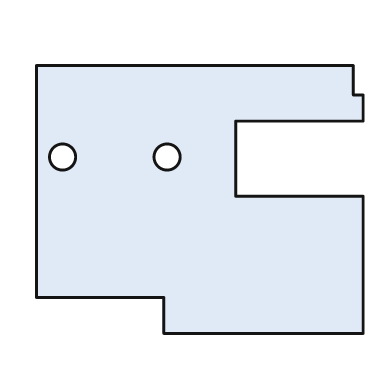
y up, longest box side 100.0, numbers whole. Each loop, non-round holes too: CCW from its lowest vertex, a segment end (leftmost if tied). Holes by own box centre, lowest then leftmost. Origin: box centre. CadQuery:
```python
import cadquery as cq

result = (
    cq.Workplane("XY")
    .moveTo(-11.0, -41.0)
    .lineTo(50.0, -41.0)
    .lineTo(50.0, 1.0)
    .lineTo(11.0, 1.0)
    .lineTo(11.0, 24.0)
    .lineTo(50.0, 24.0)
    .lineTo(50.0, 32.0)
    .lineTo(47.0, 32.0)
    .lineTo(47.0, 41.0)
    .lineTo(-50.0, 41.0)
    .lineTo(-50.0, -30.0)
    .lineTo(-11.0, -30.0)
    .close()
    .moveTo(-42.0, 13.0)
    .circle(4.0)
    .moveTo(-10.0, 13.0)
    .circle(4.0)
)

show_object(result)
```